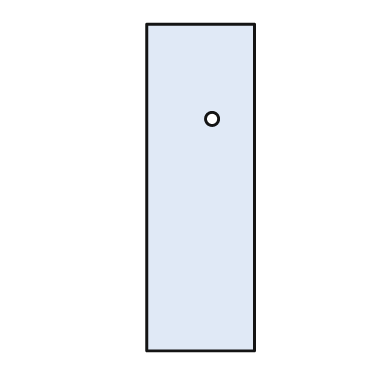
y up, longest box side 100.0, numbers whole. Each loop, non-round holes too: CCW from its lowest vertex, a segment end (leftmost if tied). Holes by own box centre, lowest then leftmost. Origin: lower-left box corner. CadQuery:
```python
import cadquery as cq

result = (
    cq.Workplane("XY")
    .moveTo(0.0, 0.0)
    .lineTo(33.0, 0.0)
    .lineTo(33.0, 100.0)
    .lineTo(0.0, 100.0)
    .close()
    .moveTo(20.0, 71.0)
    .circle(2.0)
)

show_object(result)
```